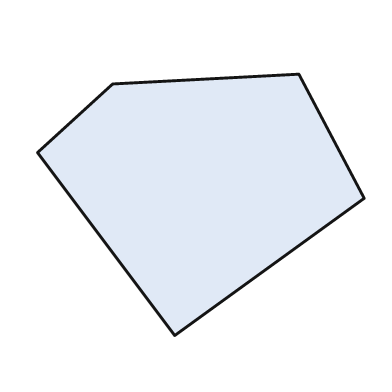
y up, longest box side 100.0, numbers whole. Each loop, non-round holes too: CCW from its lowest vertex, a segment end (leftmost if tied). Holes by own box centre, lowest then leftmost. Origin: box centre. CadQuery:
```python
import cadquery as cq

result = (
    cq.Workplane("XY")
    .moveTo(-8.0, -40.0)
    .lineTo(50.0, 2.0)
    .lineTo(30.0, 40.0)
    .lineTo(-27.0, 37.0)
    .lineTo(-50.0, 16.0)
    .close()
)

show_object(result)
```